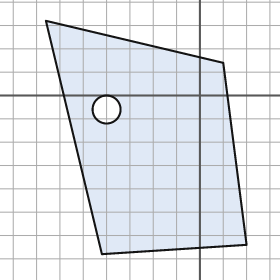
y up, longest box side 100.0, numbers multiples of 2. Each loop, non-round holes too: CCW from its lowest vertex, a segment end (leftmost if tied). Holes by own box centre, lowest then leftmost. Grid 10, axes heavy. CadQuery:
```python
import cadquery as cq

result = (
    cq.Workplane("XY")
    .moveTo(-42.0, -68.0)
    .lineTo(20.0, -64.0)
    .lineTo(10.0, 14.0)
    .lineTo(-66.0, 32.0)
    .close()
    .moveTo(-40.0, -6.0)
    .circle(6.0)
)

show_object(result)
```